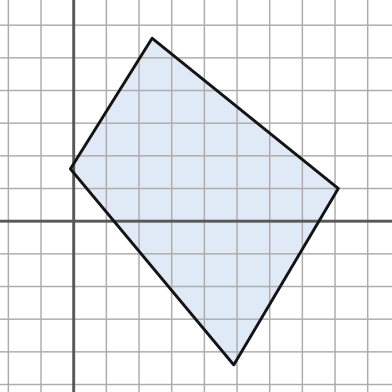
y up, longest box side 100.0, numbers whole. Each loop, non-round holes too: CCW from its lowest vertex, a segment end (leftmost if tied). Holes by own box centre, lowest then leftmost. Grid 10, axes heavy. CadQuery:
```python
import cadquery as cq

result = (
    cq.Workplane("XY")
    .moveTo(49.0, -44.0)
    .lineTo(81.0, 10.0)
    .lineTo(24.0, 56.0)
    .lineTo(-1.0, 16.0)
    .close()
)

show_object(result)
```